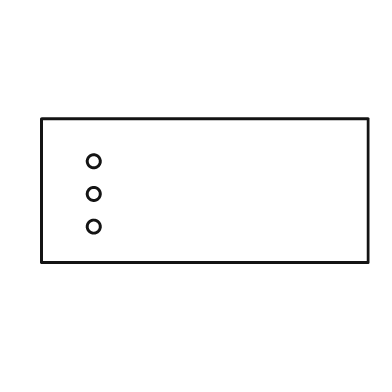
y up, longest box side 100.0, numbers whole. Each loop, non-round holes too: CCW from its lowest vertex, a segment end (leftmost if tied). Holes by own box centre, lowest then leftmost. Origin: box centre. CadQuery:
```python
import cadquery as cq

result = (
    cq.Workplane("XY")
    .moveTo(-50.0, -22.0)
    .lineTo(50.0, -22.0)
    .lineTo(50.0, 22.0)
    .lineTo(-50.0, 22.0)
    .close()
    .moveTo(-34.0, -11.0)
    .circle(2.0)
    .moveTo(-34.0, -1.0)
    .circle(2.0)
    .moveTo(-34.0, 9.0)
    .circle(2.0)
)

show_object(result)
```